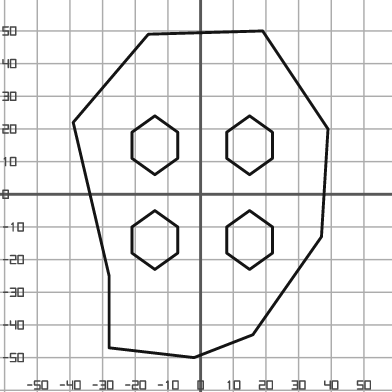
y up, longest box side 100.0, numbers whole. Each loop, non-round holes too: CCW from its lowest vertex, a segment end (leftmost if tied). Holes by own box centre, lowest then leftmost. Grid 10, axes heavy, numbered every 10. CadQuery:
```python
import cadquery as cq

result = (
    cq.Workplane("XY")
    .moveTo(-2.0, -50.0)
    .lineTo(16.0, -43.0)
    .lineTo(37.0, -13.0)
    .lineTo(39.0, 20.0)
    .lineTo(19.0, 50.0)
    .lineTo(-16.0, 49.0)
    .lineTo(-39.0, 22.0)
    .lineTo(-28.0, -25.0)
    .lineTo(-28.0, -47.0)
    .close()
    .moveTo(-14.0, -23.0)
    .lineTo(-7.0, -18.0)
    .lineTo(-7.0, -10.0)
    .lineTo(-14.0, -5.0)
    .lineTo(-21.0, -10.0)
    .lineTo(-21.0, -18.0)
    .close()
    .moveTo(15.0, -23.0)
    .lineTo(22.0, -18.0)
    .lineTo(22.0, -10.0)
    .lineTo(15.0, -5.0)
    .lineTo(8.0, -10.0)
    .lineTo(8.0, -18.0)
    .close()
    .moveTo(-14.0, 6.0)
    .lineTo(-7.0, 11.0)
    .lineTo(-7.0, 19.0)
    .lineTo(-14.0, 24.0)
    .lineTo(-21.0, 19.0)
    .lineTo(-21.0, 11.0)
    .close()
    .moveTo(15.0, 6.0)
    .lineTo(22.0, 11.0)
    .lineTo(22.0, 19.0)
    .lineTo(15.0, 24.0)
    .lineTo(8.0, 19.0)
    .lineTo(8.0, 11.0)
    .close()
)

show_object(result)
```